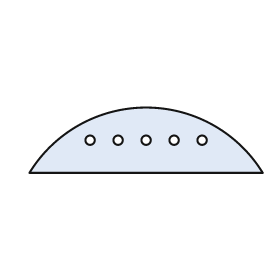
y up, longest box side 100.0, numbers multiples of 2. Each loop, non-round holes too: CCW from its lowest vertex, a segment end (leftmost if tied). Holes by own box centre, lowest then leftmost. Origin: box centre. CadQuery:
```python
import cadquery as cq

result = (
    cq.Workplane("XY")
    .moveTo(-50.0, -14.0)
    .lineTo(50.0, -14.0)
    .threePointArc((0.0, 14.0), (-50.0, -14.0))
    .close()
    .moveTo(-24.0, 0.0)
    .circle(2.0)
    .moveTo(-12.0, 0.0)
    .circle(2.0)
    .moveTo(0.0, 0.0)
    .circle(2.0)
    .moveTo(12.0, 0.0)
    .circle(2.0)
    .moveTo(24.0, 0.0)
    .circle(2.0)
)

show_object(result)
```